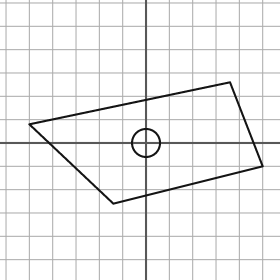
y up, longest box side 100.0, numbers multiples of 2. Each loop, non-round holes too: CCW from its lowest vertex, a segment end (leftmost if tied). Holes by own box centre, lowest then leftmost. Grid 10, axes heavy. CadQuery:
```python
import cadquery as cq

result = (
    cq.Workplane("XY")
    .moveTo(-14.0, -26.0)
    .lineTo(50.0, -10.0)
    .lineTo(36.0, 26.0)
    .lineTo(-50.0, 8.0)
    .close()
    .moveTo(0.0, 0.0)
    .circle(6.0)
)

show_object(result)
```